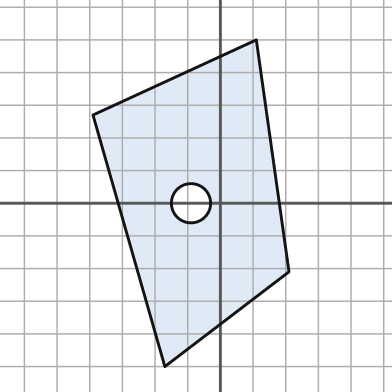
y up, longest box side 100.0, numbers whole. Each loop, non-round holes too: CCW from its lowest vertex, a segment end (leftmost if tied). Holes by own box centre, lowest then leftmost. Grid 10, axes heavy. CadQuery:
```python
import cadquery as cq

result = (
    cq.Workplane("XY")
    .moveTo(-17.0, -50.0)
    .lineTo(21.0, -21.0)
    .lineTo(11.0, 50.0)
    .lineTo(-39.0, 27.0)
    .close()
    .moveTo(-9.0, 0.0)
    .circle(6.0)
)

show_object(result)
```